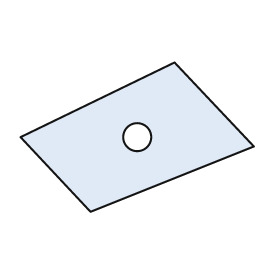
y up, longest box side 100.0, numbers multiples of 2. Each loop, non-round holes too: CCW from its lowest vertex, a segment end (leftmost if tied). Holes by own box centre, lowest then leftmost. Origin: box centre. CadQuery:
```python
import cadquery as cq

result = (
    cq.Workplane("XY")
    .moveTo(-20.0, -32.0)
    .lineTo(50.0, -4.0)
    .lineTo(16.0, 32.0)
    .lineTo(-50.0, 0.0)
    .close()
    .moveTo(0.0, 0.0)
    .circle(6.0)
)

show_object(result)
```